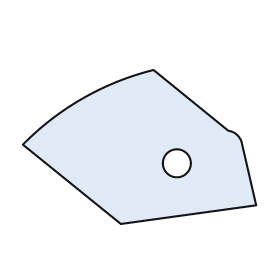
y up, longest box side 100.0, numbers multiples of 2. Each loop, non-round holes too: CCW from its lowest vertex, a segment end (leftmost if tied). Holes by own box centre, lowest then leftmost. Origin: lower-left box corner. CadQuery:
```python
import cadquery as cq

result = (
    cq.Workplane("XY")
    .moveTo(42.0, 0.0)
    .lineTo(100.0, 8.0)
    .lineTo(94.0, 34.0)
    .threePointArc((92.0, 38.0), (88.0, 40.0))
    .lineTo(56.0, 66.0)
    .threePointArc((26.0, 54.0), (0.0, 34.0))
    .close()
    .moveTo(66.0, 26.0)
    .circle(6.0)
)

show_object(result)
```